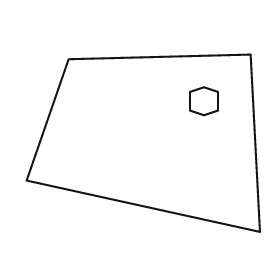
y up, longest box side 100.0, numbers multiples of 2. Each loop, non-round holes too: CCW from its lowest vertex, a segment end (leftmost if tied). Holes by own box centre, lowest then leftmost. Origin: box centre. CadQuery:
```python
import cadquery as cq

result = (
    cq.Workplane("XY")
    .moveTo(50.0, -38.0)
    .lineTo(46.0, 38.0)
    .lineTo(-32.0, 36.0)
    .lineTo(-50.0, -16.0)
    .close()
    .moveTo(26.0, 12.0)
    .lineTo(32.0, 14.0)
    .lineTo(32.0, 22.0)
    .lineTo(26.0, 24.0)
    .lineTo(20.0, 22.0)
    .lineTo(20.0, 14.0)
    .close()
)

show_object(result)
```